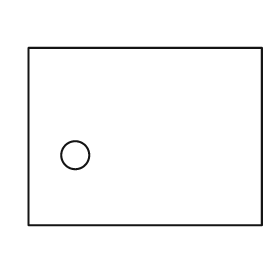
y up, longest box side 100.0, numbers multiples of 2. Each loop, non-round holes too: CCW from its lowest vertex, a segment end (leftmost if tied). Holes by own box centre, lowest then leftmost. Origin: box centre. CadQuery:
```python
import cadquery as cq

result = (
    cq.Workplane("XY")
    .moveTo(-50.0, -38.0)
    .lineTo(50.0, -38.0)
    .lineTo(50.0, 38.0)
    .lineTo(-50.0, 38.0)
    .close()
    .moveTo(-30.0, -8.0)
    .circle(6.0)
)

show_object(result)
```